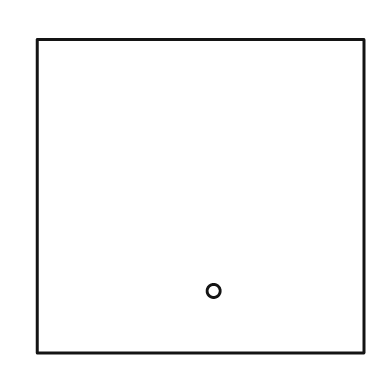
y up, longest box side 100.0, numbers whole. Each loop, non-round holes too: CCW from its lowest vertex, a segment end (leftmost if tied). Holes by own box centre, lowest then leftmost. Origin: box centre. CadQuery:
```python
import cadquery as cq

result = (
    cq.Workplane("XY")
    .moveTo(-50.0, -48.0)
    .lineTo(50.0, -48.0)
    .lineTo(50.0, 48.0)
    .lineTo(-50.0, 48.0)
    .close()
    .moveTo(4.0, -29.0)
    .circle(2.0)
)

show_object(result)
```